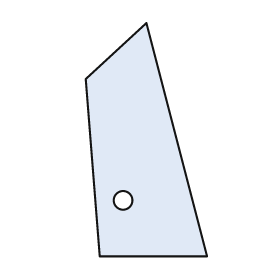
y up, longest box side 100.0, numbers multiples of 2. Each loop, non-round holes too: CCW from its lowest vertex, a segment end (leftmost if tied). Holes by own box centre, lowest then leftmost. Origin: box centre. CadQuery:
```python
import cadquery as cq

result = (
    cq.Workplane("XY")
    .moveTo(-20.0, -50.0)
    .lineTo(26.0, -50.0)
    .lineTo(0.0, 50.0)
    .lineTo(-26.0, 26.0)
    .close()
    .moveTo(-10.0, -26.0)
    .circle(4.0)
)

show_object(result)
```